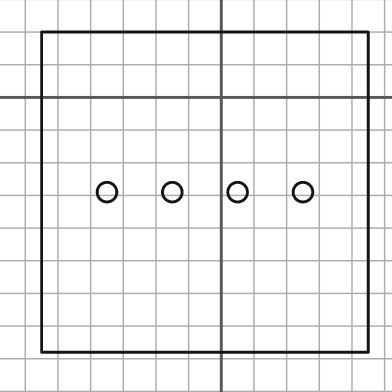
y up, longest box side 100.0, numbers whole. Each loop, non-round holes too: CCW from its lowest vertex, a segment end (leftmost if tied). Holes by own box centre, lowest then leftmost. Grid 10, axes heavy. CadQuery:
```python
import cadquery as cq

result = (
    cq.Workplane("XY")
    .moveTo(-55.0, -78.0)
    .lineTo(45.0, -78.0)
    .lineTo(45.0, 20.0)
    .lineTo(-55.0, 20.0)
    .close()
    .moveTo(-35.0, -29.0)
    .circle(3.0)
    .moveTo(-15.0, -29.0)
    .circle(3.0)
    .moveTo(5.0, -29.0)
    .circle(3.0)
    .moveTo(25.0, -29.0)
    .circle(3.0)
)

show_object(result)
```